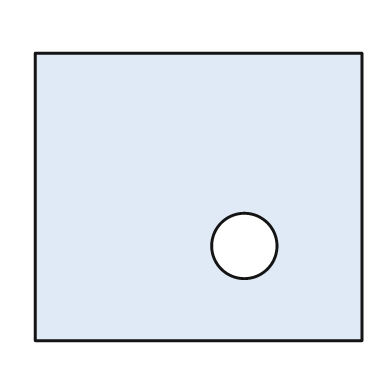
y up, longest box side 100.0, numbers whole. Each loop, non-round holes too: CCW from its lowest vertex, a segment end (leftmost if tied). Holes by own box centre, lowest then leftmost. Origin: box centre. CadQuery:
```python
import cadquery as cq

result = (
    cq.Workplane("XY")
    .moveTo(-50.0, -44.0)
    .lineTo(50.0, -44.0)
    .lineTo(50.0, 44.0)
    .lineTo(-50.0, 44.0)
    .close()
    .moveTo(14.0, -15.0)
    .circle(10.0)
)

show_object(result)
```